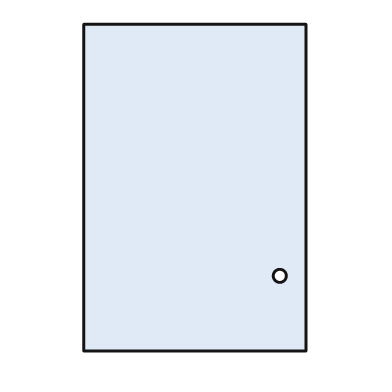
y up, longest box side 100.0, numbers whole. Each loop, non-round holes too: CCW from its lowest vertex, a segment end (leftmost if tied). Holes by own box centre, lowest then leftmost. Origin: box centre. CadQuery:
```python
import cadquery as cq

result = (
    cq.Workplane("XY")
    .moveTo(-34.0, -50.0)
    .lineTo(34.0, -50.0)
    .lineTo(34.0, 50.0)
    .lineTo(-34.0, 50.0)
    .close()
    .moveTo(26.0, -27.0)
    .circle(2.0)
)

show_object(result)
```